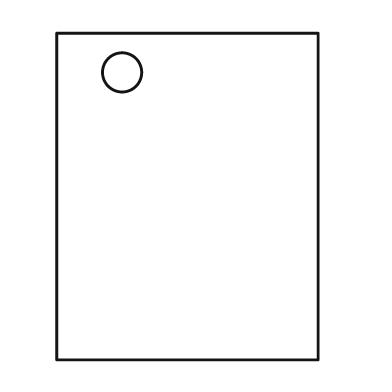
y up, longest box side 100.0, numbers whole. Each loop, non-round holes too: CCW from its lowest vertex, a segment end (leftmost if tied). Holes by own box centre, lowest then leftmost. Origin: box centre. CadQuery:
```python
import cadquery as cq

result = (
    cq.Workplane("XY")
    .moveTo(-40.0, -50.0)
    .lineTo(40.0, -50.0)
    .lineTo(40.0, 50.0)
    .lineTo(-40.0, 50.0)
    .close()
    .moveTo(-20.0, 38.0)
    .circle(6.0)
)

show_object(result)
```